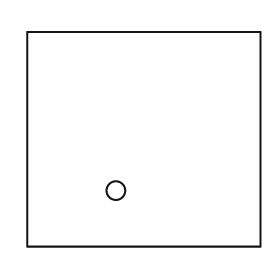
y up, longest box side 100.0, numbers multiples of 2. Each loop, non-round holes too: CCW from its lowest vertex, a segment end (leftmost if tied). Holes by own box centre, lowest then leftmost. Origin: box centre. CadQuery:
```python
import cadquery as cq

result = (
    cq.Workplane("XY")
    .moveTo(-50.0, -46.0)
    .lineTo(50.0, -46.0)
    .lineTo(50.0, 46.0)
    .lineTo(-50.0, 46.0)
    .close()
    .moveTo(-12.0, -22.0)
    .circle(4.0)
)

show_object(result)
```